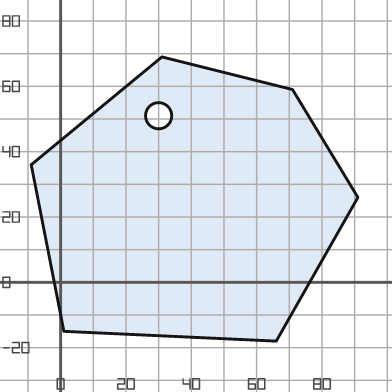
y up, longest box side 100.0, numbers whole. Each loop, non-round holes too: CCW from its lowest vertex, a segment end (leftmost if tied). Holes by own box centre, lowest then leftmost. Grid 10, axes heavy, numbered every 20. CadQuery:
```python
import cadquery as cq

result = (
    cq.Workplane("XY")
    .moveTo(66.0, -18.0)
    .lineTo(91.0, 26.0)
    .lineTo(71.0, 59.0)
    .lineTo(31.0, 69.0)
    .lineTo(-9.0, 36.0)
    .lineTo(1.0, -15.0)
    .close()
    .moveTo(30.0, 51.0)
    .circle(4.0)
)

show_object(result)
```